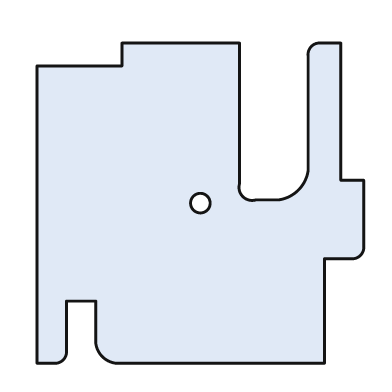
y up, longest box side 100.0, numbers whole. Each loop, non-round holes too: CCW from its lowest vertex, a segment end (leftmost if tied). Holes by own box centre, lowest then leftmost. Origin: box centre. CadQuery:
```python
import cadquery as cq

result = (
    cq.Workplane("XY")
    .moveTo(-50.0, -49.0)
    .lineTo(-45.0, -49.0)
    .threePointArc((-42.0, -48.0), (-41.0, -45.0))
    .lineTo(-41.0, -30.0)
    .lineTo(-32.0, -30.0)
    .lineTo(-32.0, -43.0)
    .threePointArc((-30.0, -47.0), (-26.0, -49.0))
    .lineTo(38.0, -49.0)
    .lineTo(38.0, -17.0)
    .lineTo(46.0, -17.0)
    .threePointArc((49.0, -16.0), (50.0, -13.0))
    .lineTo(50.0, 7.0)
    .lineTo(43.0, 7.0)
    .lineTo(43.0, 49.0)
    .lineTo(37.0, 49.0)
    .threePointArc((34.0, 48.0), (33.0, 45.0))
    .lineTo(33.0, 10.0)
    .threePointArc((30.0, 4.0), (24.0, 1.0))
    .lineTo(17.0, 1.0)
    .threePointArc((13.0, 2.0), (12.0, 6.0))
    .lineTo(12.0, 49.0)
    .lineTo(-24.0, 49.0)
    .lineTo(-24.0, 42.0)
    .lineTo(-50.0, 42.0)
    .close()
    .moveTo(0.0, 0.0)
    .circle(3.0)
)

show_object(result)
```